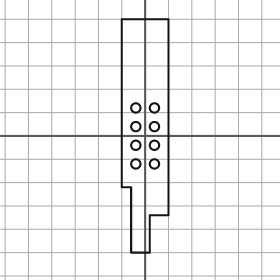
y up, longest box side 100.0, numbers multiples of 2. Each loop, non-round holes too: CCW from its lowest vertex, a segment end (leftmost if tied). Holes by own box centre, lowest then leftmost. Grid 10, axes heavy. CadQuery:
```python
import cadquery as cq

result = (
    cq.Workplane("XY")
    .moveTo(-6.0, -50.0)
    .lineTo(2.0, -50.0)
    .lineTo(2.0, -34.0)
    .lineTo(10.0, -34.0)
    .lineTo(10.0, 50.0)
    .lineTo(-10.0, 50.0)
    .lineTo(-10.0, -22.0)
    .lineTo(-6.0, -22.0)
    .close()
    .moveTo(-4.0, -12.0)
    .circle(2.0)
    .moveTo(4.0, -12.0)
    .circle(2.0)
    .moveTo(-4.0, -4.0)
    .circle(2.0)
    .moveTo(4.0, -4.0)
    .circle(2.0)
    .moveTo(-4.0, 4.0)
    .circle(2.0)
    .moveTo(4.0, 4.0)
    .circle(2.0)
    .moveTo(-4.0, 12.0)
    .circle(2.0)
    .moveTo(4.0, 12.0)
    .circle(2.0)
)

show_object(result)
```